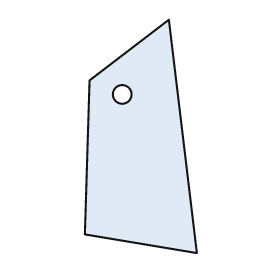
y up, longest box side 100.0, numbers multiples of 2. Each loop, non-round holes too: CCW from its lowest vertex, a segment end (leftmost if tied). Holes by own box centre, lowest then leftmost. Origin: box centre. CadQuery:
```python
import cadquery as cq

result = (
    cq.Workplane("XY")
    .moveTo(24.0, -50.0)
    .lineTo(12.0, 50.0)
    .lineTo(-22.0, 24.0)
    .lineTo(-24.0, -42.0)
    .close()
    .moveTo(-8.0, 18.0)
    .circle(4.0)
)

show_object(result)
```